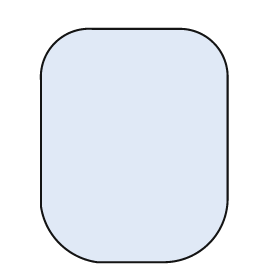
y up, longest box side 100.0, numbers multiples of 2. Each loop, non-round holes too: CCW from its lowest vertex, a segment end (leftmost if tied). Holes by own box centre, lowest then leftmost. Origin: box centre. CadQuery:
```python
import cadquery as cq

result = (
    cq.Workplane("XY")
    .moveTo(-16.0, -50.0)
    .lineTo(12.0, -50.0)
    .threePointArc((32.0, -42.0), (40.0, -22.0))
    .lineTo(40.0, 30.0)
    .threePointArc((34.0, 44.0), (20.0, 50.0))
    .lineTo(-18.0, 50.0)
    .threePointArc((-34.0, 44.0), (-40.0, 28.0))
    .lineTo(-40.0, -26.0)
    .threePointArc((-32.0, -42.0), (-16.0, -50.0))
    .close()
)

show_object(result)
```